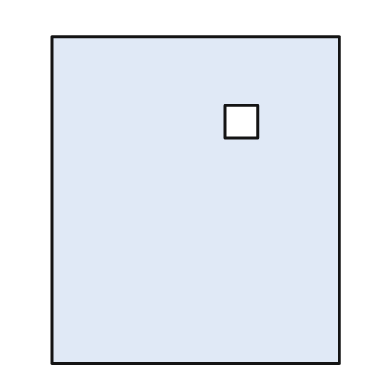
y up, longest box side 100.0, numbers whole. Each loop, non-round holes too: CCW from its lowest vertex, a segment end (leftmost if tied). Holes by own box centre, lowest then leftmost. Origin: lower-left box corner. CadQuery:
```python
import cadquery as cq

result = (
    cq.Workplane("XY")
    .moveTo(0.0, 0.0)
    .lineTo(88.0, 0.0)
    .lineTo(88.0, 100.0)
    .lineTo(0.0, 100.0)
    .close()
    .moveTo(53.0, 69.0)
    .lineTo(63.0, 69.0)
    .lineTo(63.0, 79.0)
    .lineTo(53.0, 79.0)
    .close()
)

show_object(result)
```